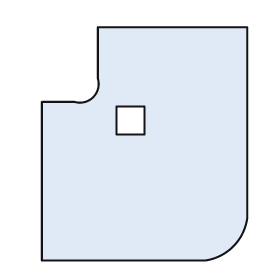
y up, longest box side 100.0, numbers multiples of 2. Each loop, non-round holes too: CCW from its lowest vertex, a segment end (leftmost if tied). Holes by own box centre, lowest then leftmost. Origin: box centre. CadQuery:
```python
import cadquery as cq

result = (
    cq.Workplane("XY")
    .moveTo(-44.0, -50.0)
    .lineTo(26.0, -50.0)
    .threePointArc((38.0, -44.0), (44.0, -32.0))
    .lineTo(44.0, 50.0)
    .lineTo(-20.0, 50.0)
    .lineTo(-20.0, 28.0)
    .threePointArc((-22.0, 20.0), (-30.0, 18.0))
    .lineTo(-44.0, 18.0)
    .close()
    .moveTo(-12.0, 4.0)
    .lineTo(0.0, 4.0)
    .lineTo(0.0, 16.0)
    .lineTo(-12.0, 16.0)
    .close()
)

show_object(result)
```